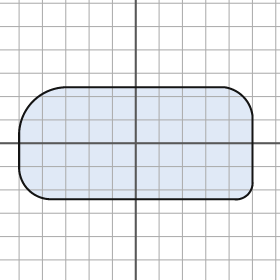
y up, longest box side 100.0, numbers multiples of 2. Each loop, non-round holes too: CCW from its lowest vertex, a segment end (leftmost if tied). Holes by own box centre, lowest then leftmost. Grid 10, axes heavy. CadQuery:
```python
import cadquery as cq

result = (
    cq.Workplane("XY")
    .moveTo(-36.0, -24.0)
    .lineTo(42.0, -24.0)
    .threePointArc((48.0, -22.0), (50.0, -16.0))
    .lineTo(50.0, 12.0)
    .threePointArc((46.0, 20.0), (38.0, 24.0))
    .lineTo(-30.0, 24.0)
    .threePointArc((-44.0, 18.0), (-50.0, 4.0))
    .lineTo(-50.0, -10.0)
    .threePointArc((-46.0, -20.0), (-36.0, -24.0))
    .close()
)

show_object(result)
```